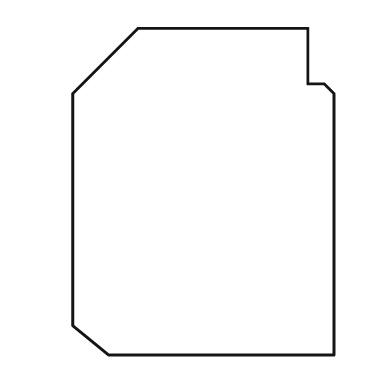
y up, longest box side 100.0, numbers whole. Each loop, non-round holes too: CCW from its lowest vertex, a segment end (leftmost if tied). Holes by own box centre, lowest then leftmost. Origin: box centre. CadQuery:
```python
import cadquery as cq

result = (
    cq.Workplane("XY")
    .moveTo(-29.0, -50.0)
    .lineTo(40.0, -50.0)
    .lineTo(40.0, 30.0)
    .lineTo(37.0, 33.0)
    .lineTo(32.0, 33.0)
    .lineTo(32.0, 50.0)
    .lineTo(-20.0, 50.0)
    .lineTo(-40.0, 30.0)
    .lineTo(-40.0, -41.0)
    .close()
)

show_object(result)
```